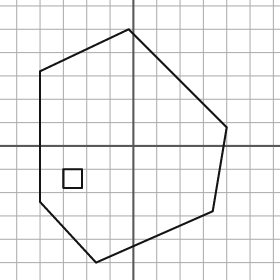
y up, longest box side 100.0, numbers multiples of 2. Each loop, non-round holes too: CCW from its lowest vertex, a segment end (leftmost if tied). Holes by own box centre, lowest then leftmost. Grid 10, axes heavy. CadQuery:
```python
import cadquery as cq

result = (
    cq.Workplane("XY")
    .moveTo(-16.0, -50.0)
    .lineTo(34.0, -28.0)
    .lineTo(40.0, 8.0)
    .lineTo(-2.0, 50.0)
    .lineTo(-40.0, 32.0)
    .lineTo(-40.0, -24.0)
    .close()
    .moveTo(-30.0, -18.0)
    .lineTo(-22.0, -18.0)
    .lineTo(-22.0, -10.0)
    .lineTo(-30.0, -10.0)
    .close()
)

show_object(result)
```